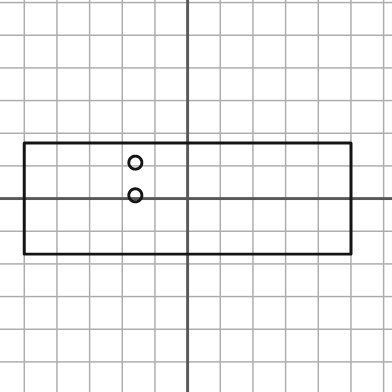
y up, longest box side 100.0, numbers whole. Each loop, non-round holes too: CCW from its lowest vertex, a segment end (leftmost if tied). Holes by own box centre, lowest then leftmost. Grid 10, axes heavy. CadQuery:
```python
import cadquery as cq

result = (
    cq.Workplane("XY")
    .moveTo(-50.0, -17.0)
    .lineTo(50.0, -17.0)
    .lineTo(50.0, 17.0)
    .lineTo(-50.0, 17.0)
    .close()
    .moveTo(-16.0, 1.0)
    .circle(2.0)
    .moveTo(-16.0, 11.0)
    .circle(2.0)
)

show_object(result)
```